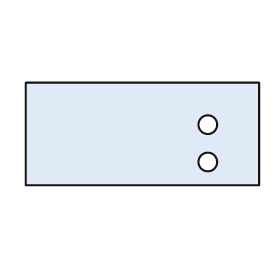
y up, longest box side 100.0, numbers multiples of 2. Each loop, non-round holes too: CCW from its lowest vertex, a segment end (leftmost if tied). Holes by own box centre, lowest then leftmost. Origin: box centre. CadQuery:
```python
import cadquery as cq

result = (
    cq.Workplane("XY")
    .moveTo(-50.0, -22.0)
    .lineTo(50.0, -22.0)
    .lineTo(50.0, 22.0)
    .lineTo(-50.0, 22.0)
    .close()
    .moveTo(28.0, -12.0)
    .circle(4.0)
    .moveTo(28.0, 4.0)
    .circle(4.0)
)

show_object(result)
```